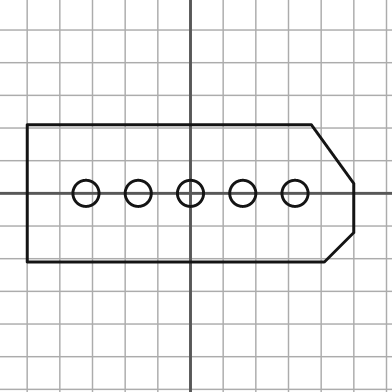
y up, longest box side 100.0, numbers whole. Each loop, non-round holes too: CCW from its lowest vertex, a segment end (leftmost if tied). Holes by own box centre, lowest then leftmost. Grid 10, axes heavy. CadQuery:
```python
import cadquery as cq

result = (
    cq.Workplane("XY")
    .moveTo(-50.0, -21.0)
    .lineTo(41.0, -21.0)
    .lineTo(50.0, -12.0)
    .lineTo(50.0, 3.0)
    .lineTo(37.0, 21.0)
    .lineTo(-50.0, 21.0)
    .close()
    .moveTo(-32.0, 0.0)
    .circle(4.0)
    .moveTo(-16.0, 0.0)
    .circle(4.0)
    .moveTo(0.0, 0.0)
    .circle(4.0)
    .moveTo(16.0, 0.0)
    .circle(4.0)
    .moveTo(32.0, 0.0)
    .circle(4.0)
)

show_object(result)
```